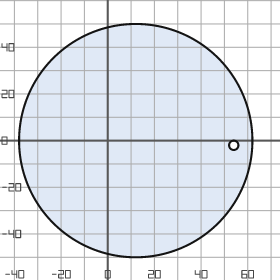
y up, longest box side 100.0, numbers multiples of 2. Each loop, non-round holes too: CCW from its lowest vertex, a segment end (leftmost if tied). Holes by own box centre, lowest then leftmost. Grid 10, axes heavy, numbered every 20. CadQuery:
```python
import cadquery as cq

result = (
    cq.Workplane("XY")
    .moveTo(12.0, 0.0)
    .circle(50.0)
    .moveTo(54.0, -2.0)
    .circle(2.0)
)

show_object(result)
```